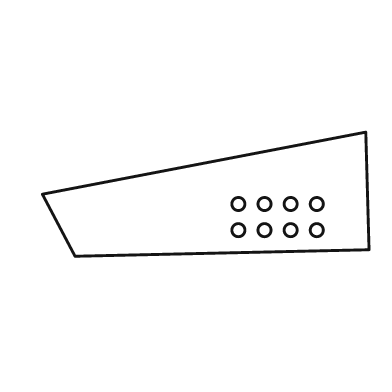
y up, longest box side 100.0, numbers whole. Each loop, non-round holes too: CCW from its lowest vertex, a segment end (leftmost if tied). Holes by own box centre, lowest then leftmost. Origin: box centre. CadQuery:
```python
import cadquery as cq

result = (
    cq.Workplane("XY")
    .moveTo(-40.0, -19.0)
    .lineTo(50.0, -17.0)
    .lineTo(49.0, 19.0)
    .lineTo(-50.0, 0.0)
    .close()
    .moveTo(10.0, -11.0)
    .circle(2.0)
    .moveTo(18.0, -11.0)
    .circle(2.0)
    .moveTo(26.0, -11.0)
    .circle(2.0)
    .moveTo(34.0, -11.0)
    .circle(2.0)
    .moveTo(10.0, -3.0)
    .circle(2.0)
    .moveTo(18.0, -3.0)
    .circle(2.0)
    .moveTo(26.0, -3.0)
    .circle(2.0)
    .moveTo(34.0, -3.0)
    .circle(2.0)
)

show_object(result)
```